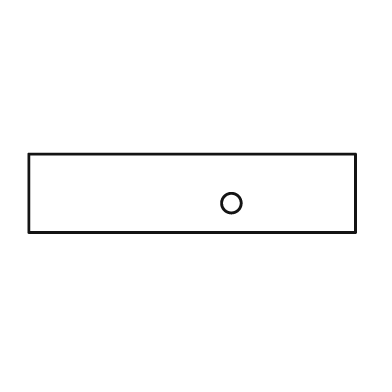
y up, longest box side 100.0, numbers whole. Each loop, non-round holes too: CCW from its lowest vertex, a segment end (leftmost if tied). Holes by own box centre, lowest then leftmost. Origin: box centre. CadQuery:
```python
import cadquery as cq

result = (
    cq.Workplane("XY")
    .moveTo(-50.0, -12.0)
    .lineTo(50.0, -12.0)
    .lineTo(50.0, 12.0)
    .lineTo(-50.0, 12.0)
    .close()
    .moveTo(12.0, -3.0)
    .circle(3.0)
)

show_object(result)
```